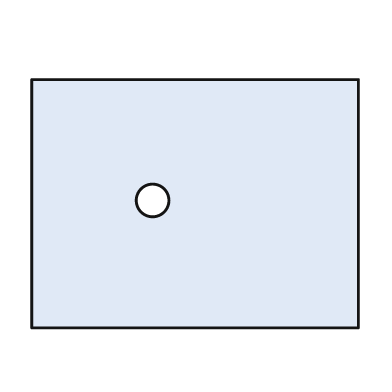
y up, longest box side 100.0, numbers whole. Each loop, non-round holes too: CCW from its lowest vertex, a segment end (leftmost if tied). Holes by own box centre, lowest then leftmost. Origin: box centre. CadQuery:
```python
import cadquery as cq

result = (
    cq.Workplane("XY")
    .moveTo(-50.0, -38.0)
    .lineTo(50.0, -38.0)
    .lineTo(50.0, 38.0)
    .lineTo(-50.0, 38.0)
    .close()
    .moveTo(-13.0, 1.0)
    .circle(5.0)
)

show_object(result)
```